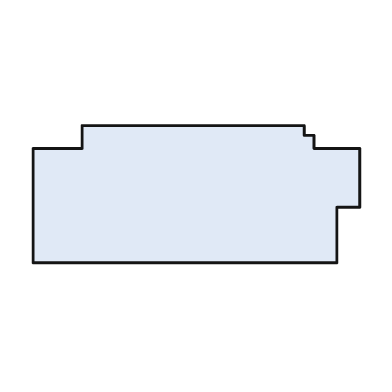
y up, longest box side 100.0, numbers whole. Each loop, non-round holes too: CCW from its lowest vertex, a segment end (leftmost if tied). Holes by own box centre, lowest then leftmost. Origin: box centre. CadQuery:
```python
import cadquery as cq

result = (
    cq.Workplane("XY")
    .moveTo(-50.0, -21.0)
    .lineTo(43.0, -21.0)
    .lineTo(43.0, -4.0)
    .lineTo(50.0, -4.0)
    .lineTo(50.0, 14.0)
    .lineTo(36.0, 14.0)
    .lineTo(36.0, 18.0)
    .lineTo(33.0, 18.0)
    .lineTo(33.0, 21.0)
    .lineTo(-35.0, 21.0)
    .lineTo(-35.0, 14.0)
    .lineTo(-50.0, 14.0)
    .close()
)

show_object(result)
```